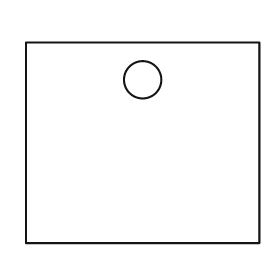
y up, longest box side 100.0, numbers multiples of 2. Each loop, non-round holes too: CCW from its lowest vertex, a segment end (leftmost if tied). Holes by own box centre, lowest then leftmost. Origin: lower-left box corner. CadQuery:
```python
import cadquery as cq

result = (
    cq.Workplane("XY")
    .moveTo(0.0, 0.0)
    .lineTo(100.0, 0.0)
    .lineTo(100.0, 86.0)
    .lineTo(0.0, 86.0)
    .close()
    .moveTo(50.0, 70.0)
    .circle(8.0)
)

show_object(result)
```